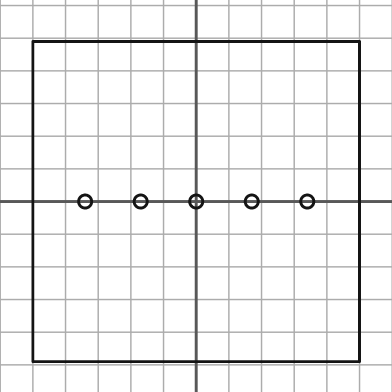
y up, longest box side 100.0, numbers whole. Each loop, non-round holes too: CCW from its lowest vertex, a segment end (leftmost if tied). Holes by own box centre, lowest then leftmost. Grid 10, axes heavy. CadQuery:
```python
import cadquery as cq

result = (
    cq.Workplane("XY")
    .moveTo(-50.0, -49.0)
    .lineTo(50.0, -49.0)
    .lineTo(50.0, 49.0)
    .lineTo(-50.0, 49.0)
    .close()
    .moveTo(-34.0, 0.0)
    .circle(2.0)
    .moveTo(-17.0, 0.0)
    .circle(2.0)
    .moveTo(0.0, 0.0)
    .circle(2.0)
    .moveTo(17.0, 0.0)
    .circle(2.0)
    .moveTo(34.0, 0.0)
    .circle(2.0)
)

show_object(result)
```